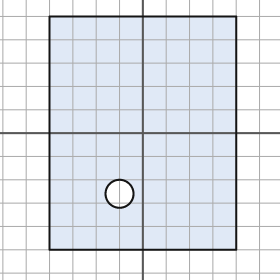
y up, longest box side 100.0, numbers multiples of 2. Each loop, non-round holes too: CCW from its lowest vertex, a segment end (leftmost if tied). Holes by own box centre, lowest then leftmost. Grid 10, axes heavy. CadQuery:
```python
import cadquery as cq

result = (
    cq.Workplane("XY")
    .moveTo(-40.0, -50.0)
    .lineTo(40.0, -50.0)
    .lineTo(40.0, 50.0)
    .lineTo(-40.0, 50.0)
    .close()
    .moveTo(-10.0, -26.0)
    .circle(6.0)
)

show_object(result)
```